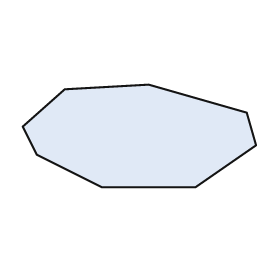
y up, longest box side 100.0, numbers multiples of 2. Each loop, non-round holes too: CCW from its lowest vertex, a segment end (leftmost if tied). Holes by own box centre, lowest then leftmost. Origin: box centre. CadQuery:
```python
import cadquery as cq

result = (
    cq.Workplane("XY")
    .moveTo(-16.0, -22.0)
    .lineTo(24.0, -22.0)
    .lineTo(50.0, -4.0)
    .lineTo(46.0, 10.0)
    .lineTo(4.0, 22.0)
    .lineTo(-32.0, 20.0)
    .lineTo(-50.0, 4.0)
    .lineTo(-44.0, -8.0)
    .close()
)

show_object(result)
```